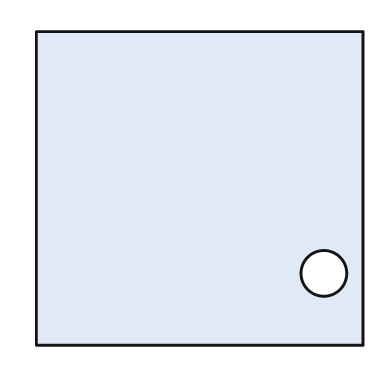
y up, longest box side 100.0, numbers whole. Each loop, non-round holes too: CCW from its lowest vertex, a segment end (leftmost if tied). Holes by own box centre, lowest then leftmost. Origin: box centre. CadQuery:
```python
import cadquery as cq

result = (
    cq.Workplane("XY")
    .moveTo(-50.0, -48.0)
    .lineTo(50.0, -48.0)
    .lineTo(50.0, 48.0)
    .lineTo(-50.0, 48.0)
    .close()
    .moveTo(38.0, -26.0)
    .circle(7.0)
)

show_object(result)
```